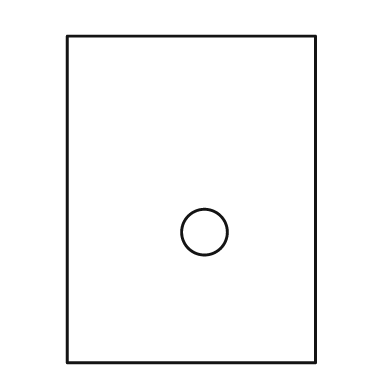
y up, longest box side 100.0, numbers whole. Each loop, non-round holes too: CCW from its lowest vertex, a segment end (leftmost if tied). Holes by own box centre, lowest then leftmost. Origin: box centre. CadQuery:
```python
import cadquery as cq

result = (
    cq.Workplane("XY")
    .moveTo(-38.0, -50.0)
    .lineTo(38.0, -50.0)
    .lineTo(38.0, 50.0)
    .lineTo(-38.0, 50.0)
    .close()
    .moveTo(4.0, -10.0)
    .circle(7.0)
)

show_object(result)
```